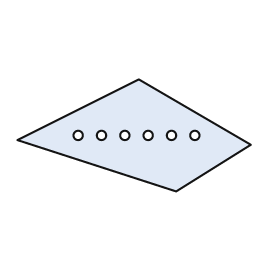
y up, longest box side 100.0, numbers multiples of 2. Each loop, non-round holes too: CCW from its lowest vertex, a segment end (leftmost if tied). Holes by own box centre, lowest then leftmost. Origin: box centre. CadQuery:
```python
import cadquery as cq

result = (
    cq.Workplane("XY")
    .moveTo(18.0, -24.0)
    .lineTo(50.0, -4.0)
    .lineTo(2.0, 24.0)
    .lineTo(-50.0, -2.0)
    .close()
    .moveTo(-24.0, 0.0)
    .circle(2.0)
    .moveTo(-14.0, 0.0)
    .circle(2.0)
    .moveTo(-4.0, 0.0)
    .circle(2.0)
    .moveTo(6.0, 0.0)
    .circle(2.0)
    .moveTo(16.0, 0.0)
    .circle(2.0)
    .moveTo(26.0, 0.0)
    .circle(2.0)
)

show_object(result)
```